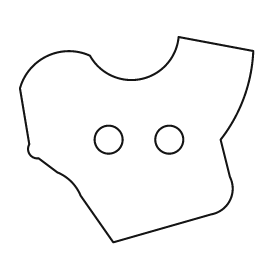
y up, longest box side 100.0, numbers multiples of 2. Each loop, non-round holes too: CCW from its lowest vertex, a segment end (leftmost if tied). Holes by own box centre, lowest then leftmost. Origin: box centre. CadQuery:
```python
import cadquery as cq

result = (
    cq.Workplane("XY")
    .moveTo(-10.0, -44.0)
    .lineTo(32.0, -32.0)
    .threePointArc((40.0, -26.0), (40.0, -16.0))
    .lineTo(36.0, 0.0)
    .threePointArc((46.0, 18.0), (50.0, 38.0))
    .lineTo(18.0, 44.0)
    .threePointArc((2.0, 26.0), (-20.0, 36.0))
    .threePointArc((-38.0, 36.0), (-50.0, 22.0))
    .lineTo(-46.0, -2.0)
    .threePointArc((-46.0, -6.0), (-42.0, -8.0))
    .lineTo(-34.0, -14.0)
    .threePointArc((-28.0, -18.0), (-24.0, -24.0))
    .close()
    .moveTo(-12.0, 0.0)
    .circle(6.0)
    .moveTo(14.0, 0.0)
    .circle(6.0)
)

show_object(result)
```